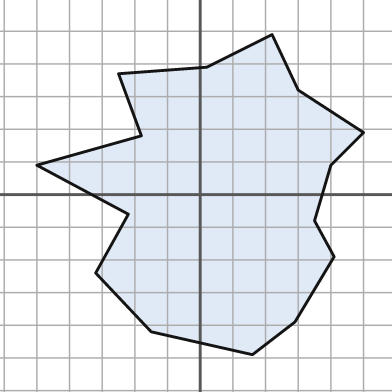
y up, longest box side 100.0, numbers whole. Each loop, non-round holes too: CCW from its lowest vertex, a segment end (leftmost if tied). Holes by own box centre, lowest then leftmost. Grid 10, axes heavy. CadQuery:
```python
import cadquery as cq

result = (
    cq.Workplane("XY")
    .moveTo(16.0, -49.0)
    .lineTo(29.0, -39.0)
    .lineTo(41.0, -19.0)
    .lineTo(35.0, -8.0)
    .lineTo(40.0, 9.0)
    .lineTo(50.0, 19.0)
    .lineTo(30.0, 32.0)
    .lineTo(22.0, 49.0)
    .lineTo(2.0, 39.0)
    .lineTo(-25.0, 37.0)
    .lineTo(-18.0, 18.0)
    .lineTo(-50.0, 9.0)
    .lineTo(-22.0, -6.0)
    .lineTo(-32.0, -24.0)
    .lineTo(-15.0, -42.0)
    .close()
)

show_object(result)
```